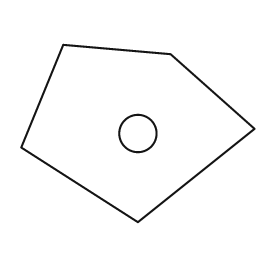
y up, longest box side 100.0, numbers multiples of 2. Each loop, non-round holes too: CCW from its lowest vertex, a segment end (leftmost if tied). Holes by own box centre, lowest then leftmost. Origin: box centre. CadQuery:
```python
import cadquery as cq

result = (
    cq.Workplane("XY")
    .moveTo(0.0, -38.0)
    .lineTo(50.0, 2.0)
    .lineTo(14.0, 34.0)
    .lineTo(-32.0, 38.0)
    .lineTo(-50.0, -6.0)
    .close()
    .moveTo(0.0, 0.0)
    .circle(8.0)
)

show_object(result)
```